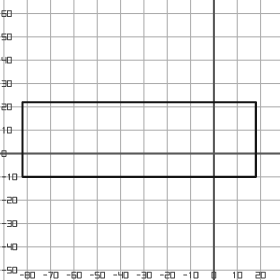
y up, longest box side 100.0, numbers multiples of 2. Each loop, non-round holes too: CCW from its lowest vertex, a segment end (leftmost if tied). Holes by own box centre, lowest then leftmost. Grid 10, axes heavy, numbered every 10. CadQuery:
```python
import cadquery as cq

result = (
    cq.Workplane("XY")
    .moveTo(-82.0, -10.0)
    .lineTo(18.0, -10.0)
    .lineTo(18.0, 22.0)
    .lineTo(-82.0, 22.0)
    .close()
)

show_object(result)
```